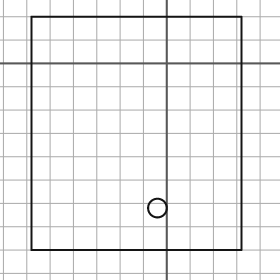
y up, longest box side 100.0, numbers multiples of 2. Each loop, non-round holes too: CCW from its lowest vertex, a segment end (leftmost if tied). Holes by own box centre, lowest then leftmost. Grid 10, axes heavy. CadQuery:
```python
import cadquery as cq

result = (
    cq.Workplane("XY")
    .moveTo(-58.0, -80.0)
    .lineTo(32.0, -80.0)
    .lineTo(32.0, 20.0)
    .lineTo(-58.0, 20.0)
    .close()
    .moveTo(-4.0, -62.0)
    .circle(4.0)
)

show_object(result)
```